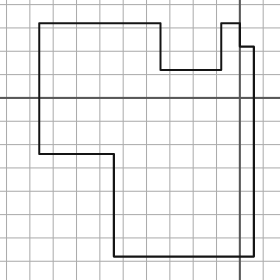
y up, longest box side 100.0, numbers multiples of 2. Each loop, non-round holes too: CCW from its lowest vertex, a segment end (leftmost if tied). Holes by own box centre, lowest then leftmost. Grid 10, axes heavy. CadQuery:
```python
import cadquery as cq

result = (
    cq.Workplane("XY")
    .moveTo(-54.0, -68.0)
    .lineTo(6.0, -68.0)
    .lineTo(6.0, 22.0)
    .lineTo(0.0, 22.0)
    .lineTo(0.0, 32.0)
    .lineTo(-8.0, 32.0)
    .lineTo(-8.0, 12.0)
    .lineTo(-34.0, 12.0)
    .lineTo(-34.0, 32.0)
    .lineTo(-86.0, 32.0)
    .lineTo(-86.0, -24.0)
    .lineTo(-54.0, -24.0)
    .close()
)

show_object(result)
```